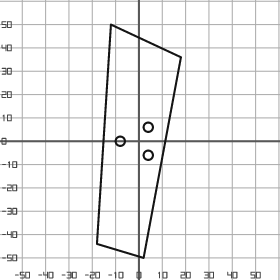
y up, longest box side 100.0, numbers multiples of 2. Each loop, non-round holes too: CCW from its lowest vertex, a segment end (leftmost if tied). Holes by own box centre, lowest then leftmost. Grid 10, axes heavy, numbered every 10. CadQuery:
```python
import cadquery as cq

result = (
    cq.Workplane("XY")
    .moveTo(2.0, -50.0)
    .lineTo(18.0, 36.0)
    .lineTo(-12.0, 50.0)
    .lineTo(-18.0, -44.0)
    .close()
    .moveTo(4.0, -6.0)
    .circle(2.0)
    .moveTo(-8.0, 0.0)
    .circle(2.0)
    .moveTo(4.0, 6.0)
    .circle(2.0)
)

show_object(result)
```